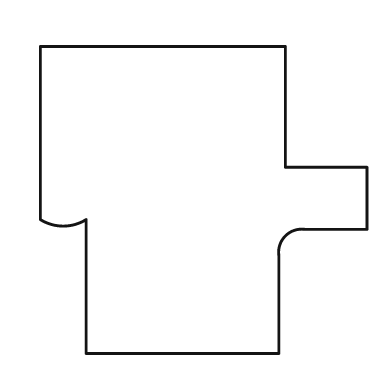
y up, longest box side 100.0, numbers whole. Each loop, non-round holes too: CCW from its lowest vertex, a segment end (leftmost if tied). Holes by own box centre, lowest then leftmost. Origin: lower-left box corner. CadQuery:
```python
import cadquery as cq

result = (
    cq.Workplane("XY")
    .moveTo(14.0, 0.0)
    .lineTo(73.0, 0.0)
    .lineTo(73.0, 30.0)
    .threePointArc((75.0, 36.0), (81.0, 38.0))
    .lineTo(100.0, 38.0)
    .lineTo(100.0, 57.0)
    .lineTo(75.0, 57.0)
    .lineTo(75.0, 94.0)
    .lineTo(0.0, 94.0)
    .lineTo(0.0, 41.0)
    .threePointArc((7.0, 39.0), (14.0, 41.0))
    .close()
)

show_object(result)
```